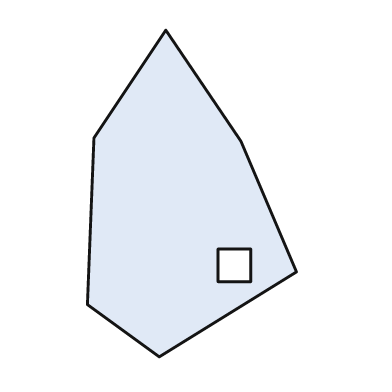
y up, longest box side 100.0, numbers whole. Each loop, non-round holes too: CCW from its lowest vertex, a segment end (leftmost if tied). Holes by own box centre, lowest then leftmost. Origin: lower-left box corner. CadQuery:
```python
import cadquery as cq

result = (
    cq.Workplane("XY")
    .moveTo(22.0, 0.0)
    .lineTo(64.0, 26.0)
    .lineTo(47.0, 66.0)
    .lineTo(24.0, 100.0)
    .lineTo(2.0, 67.0)
    .lineTo(0.0, 16.0)
    .close()
    .moveTo(40.0, 23.0)
    .lineTo(50.0, 23.0)
    .lineTo(50.0, 33.0)
    .lineTo(40.0, 33.0)
    .close()
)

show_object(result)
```